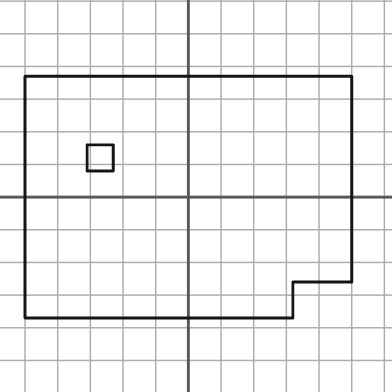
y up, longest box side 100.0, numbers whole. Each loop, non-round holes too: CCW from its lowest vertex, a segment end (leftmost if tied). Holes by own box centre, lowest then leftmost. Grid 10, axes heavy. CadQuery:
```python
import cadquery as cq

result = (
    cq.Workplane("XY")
    .moveTo(-50.0, -37.0)
    .lineTo(32.0, -37.0)
    .lineTo(32.0, -26.0)
    .lineTo(50.0, -26.0)
    .lineTo(50.0, 37.0)
    .lineTo(-50.0, 37.0)
    .close()
    .moveTo(-31.0, 8.0)
    .lineTo(-23.0, 8.0)
    .lineTo(-23.0, 16.0)
    .lineTo(-31.0, 16.0)
    .close()
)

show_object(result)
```